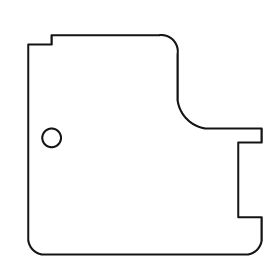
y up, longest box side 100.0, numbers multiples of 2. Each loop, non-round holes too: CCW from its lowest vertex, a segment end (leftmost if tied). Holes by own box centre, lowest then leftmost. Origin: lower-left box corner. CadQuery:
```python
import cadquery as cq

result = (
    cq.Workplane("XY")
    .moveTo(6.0, 0.0)
    .lineTo(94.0, 0.0)
    .threePointArc((98.0, 2.0), (100.0, 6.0))
    .lineTo(100.0, 16.0)
    .lineTo(90.0, 16.0)
    .lineTo(90.0, 48.0)
    .lineTo(100.0, 48.0)
    .lineTo(100.0, 54.0)
    .lineTo(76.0, 54.0)
    .threePointArc((68.0, 58.0), (64.0, 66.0))
    .lineTo(64.0, 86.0)
    .threePointArc((62.0, 92.0), (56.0, 94.0))
    .lineTo(10.0, 94.0)
    .lineTo(10.0, 90.0)
    .lineTo(0.0, 90.0)
    .lineTo(0.0, 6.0)
    .threePointArc((2.0, 2.0), (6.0, 0.0))
    .close()
    .moveTo(10.0, 50.0)
    .circle(4.0)
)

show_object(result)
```